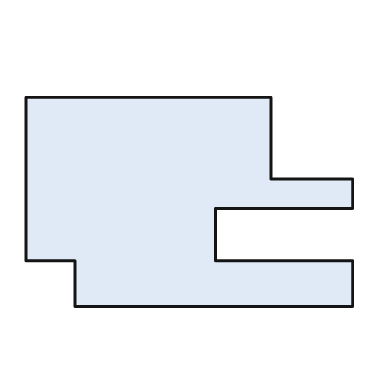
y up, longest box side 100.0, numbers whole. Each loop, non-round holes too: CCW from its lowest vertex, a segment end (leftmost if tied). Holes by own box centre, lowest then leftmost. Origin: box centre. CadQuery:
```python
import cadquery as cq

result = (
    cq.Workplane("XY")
    .moveTo(-35.0, -32.0)
    .lineTo(50.0, -32.0)
    .lineTo(50.0, -18.0)
    .lineTo(8.0, -18.0)
    .lineTo(8.0, -2.0)
    .lineTo(50.0, -2.0)
    .lineTo(50.0, 7.0)
    .lineTo(25.0, 7.0)
    .lineTo(25.0, 32.0)
    .lineTo(-50.0, 32.0)
    .lineTo(-50.0, -18.0)
    .lineTo(-35.0, -18.0)
    .close()
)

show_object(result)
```